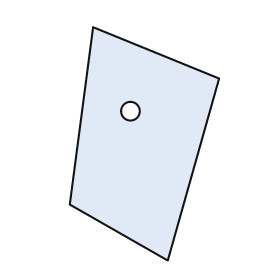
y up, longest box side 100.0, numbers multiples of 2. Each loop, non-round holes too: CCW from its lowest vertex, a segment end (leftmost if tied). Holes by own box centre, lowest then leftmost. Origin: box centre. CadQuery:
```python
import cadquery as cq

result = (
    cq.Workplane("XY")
    .moveTo(10.0, -50.0)
    .lineTo(32.0, 28.0)
    .lineTo(-22.0, 50.0)
    .lineTo(-32.0, -26.0)
    .close()
    .moveTo(-6.0, 14.0)
    .circle(4.0)
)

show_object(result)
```